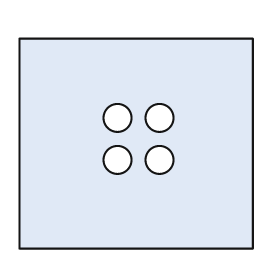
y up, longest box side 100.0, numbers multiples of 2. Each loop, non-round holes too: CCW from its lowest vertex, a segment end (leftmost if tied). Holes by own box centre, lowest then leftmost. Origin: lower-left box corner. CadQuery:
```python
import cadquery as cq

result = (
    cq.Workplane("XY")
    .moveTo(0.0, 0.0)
    .lineTo(100.0, 0.0)
    .lineTo(100.0, 90.0)
    .lineTo(0.0, 90.0)
    .close()
    .moveTo(42.0, 38.0)
    .circle(6.0)
    .moveTo(60.0, 38.0)
    .circle(6.0)
    .moveTo(42.0, 56.0)
    .circle(6.0)
    .moveTo(60.0, 56.0)
    .circle(6.0)
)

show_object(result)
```